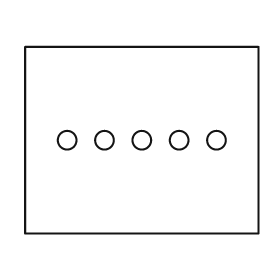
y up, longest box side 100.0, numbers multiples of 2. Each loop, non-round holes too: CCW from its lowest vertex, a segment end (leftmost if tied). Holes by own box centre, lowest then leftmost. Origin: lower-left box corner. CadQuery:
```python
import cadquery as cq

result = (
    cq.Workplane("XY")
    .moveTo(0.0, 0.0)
    .lineTo(100.0, 0.0)
    .lineTo(100.0, 80.0)
    .lineTo(0.0, 80.0)
    .close()
    .moveTo(18.0, 40.0)
    .circle(4.0)
    .moveTo(34.0, 40.0)
    .circle(4.0)
    .moveTo(50.0, 40.0)
    .circle(4.0)
    .moveTo(66.0, 40.0)
    .circle(4.0)
    .moveTo(82.0, 40.0)
    .circle(4.0)
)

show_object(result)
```